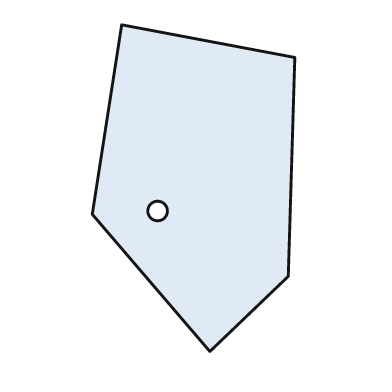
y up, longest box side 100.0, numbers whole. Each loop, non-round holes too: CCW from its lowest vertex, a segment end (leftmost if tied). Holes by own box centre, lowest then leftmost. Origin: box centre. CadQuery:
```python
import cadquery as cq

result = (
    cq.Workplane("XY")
    .moveTo(5.0, -50.0)
    .lineTo(29.0, -27.0)
    .lineTo(31.0, 40.0)
    .lineTo(-22.0, 50.0)
    .lineTo(-31.0, -8.0)
    .close()
    .moveTo(-11.0, -7.0)
    .circle(3.0)
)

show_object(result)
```